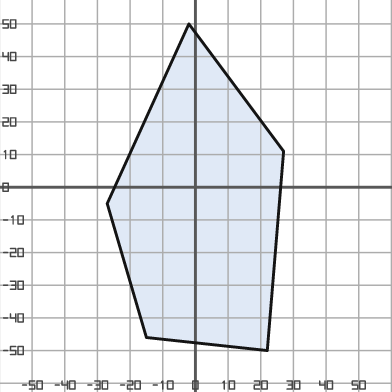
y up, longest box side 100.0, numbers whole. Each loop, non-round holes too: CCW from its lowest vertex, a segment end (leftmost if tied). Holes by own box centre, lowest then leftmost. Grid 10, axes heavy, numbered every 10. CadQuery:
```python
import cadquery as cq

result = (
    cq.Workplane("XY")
    .moveTo(22.0, -50.0)
    .lineTo(27.0, 11.0)
    .lineTo(-2.0, 50.0)
    .lineTo(-27.0, -5.0)
    .lineTo(-15.0, -46.0)
    .close()
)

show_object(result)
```